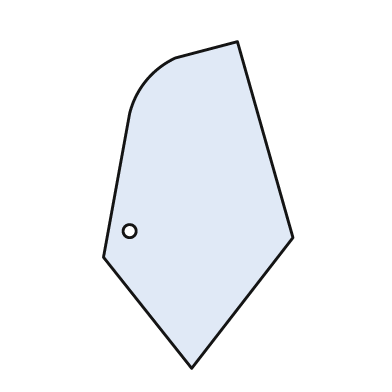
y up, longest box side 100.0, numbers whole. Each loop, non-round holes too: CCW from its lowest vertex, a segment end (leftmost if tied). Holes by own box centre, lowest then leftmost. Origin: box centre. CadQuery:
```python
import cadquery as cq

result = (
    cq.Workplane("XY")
    .moveTo(-2.0, -50.0)
    .lineTo(29.0, -10.0)
    .lineTo(12.0, 50.0)
    .lineTo(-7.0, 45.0)
    .threePointArc((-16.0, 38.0), (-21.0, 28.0))
    .lineTo(-29.0, -16.0)
    .close()
    .moveTo(-21.0, -8.0)
    .circle(2.0)
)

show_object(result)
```